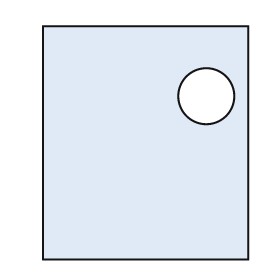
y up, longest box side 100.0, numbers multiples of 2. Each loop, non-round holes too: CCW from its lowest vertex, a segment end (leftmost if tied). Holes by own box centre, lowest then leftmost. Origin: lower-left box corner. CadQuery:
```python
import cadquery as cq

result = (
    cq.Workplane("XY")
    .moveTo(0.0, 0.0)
    .lineTo(88.0, 0.0)
    .lineTo(88.0, 100.0)
    .lineTo(0.0, 100.0)
    .close()
    .moveTo(70.0, 70.0)
    .circle(12.0)
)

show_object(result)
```